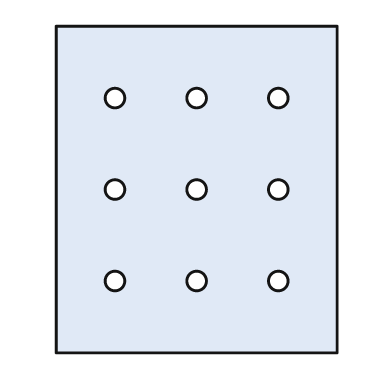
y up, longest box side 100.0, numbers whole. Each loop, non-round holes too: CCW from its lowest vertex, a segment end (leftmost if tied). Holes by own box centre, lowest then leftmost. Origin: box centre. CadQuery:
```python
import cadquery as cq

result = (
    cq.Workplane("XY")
    .moveTo(-43.0, -50.0)
    .lineTo(43.0, -50.0)
    .lineTo(43.0, 50.0)
    .lineTo(-43.0, 50.0)
    .close()
    .moveTo(-25.0, -28.0)
    .circle(3.0)
    .moveTo(0.0, -28.0)
    .circle(3.0)
    .moveTo(25.0, -28.0)
    .circle(3.0)
    .moveTo(-25.0, 0.0)
    .circle(3.0)
    .moveTo(0.0, 0.0)
    .circle(3.0)
    .moveTo(25.0, 0.0)
    .circle(3.0)
    .moveTo(-25.0, 28.0)
    .circle(3.0)
    .moveTo(0.0, 28.0)
    .circle(3.0)
    .moveTo(25.0, 28.0)
    .circle(3.0)
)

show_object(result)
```